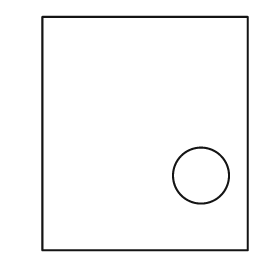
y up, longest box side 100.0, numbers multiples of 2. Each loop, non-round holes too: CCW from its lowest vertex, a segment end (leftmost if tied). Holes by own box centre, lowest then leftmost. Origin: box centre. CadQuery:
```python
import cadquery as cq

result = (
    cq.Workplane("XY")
    .moveTo(-44.0, -50.0)
    .lineTo(44.0, -50.0)
    .lineTo(44.0, 50.0)
    .lineTo(-44.0, 50.0)
    .close()
    .moveTo(24.0, -18.0)
    .circle(12.0)
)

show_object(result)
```